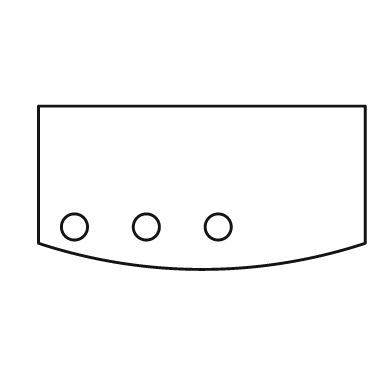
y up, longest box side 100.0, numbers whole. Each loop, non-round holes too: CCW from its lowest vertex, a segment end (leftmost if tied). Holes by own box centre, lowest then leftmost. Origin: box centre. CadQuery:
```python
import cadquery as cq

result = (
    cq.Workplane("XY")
    .moveTo(-50.0, -17.0)
    .threePointArc((0.0, -25.0), (50.0, -17.0))
    .lineTo(50.0, 25.0)
    .lineTo(-50.0, 25.0)
    .close()
    .moveTo(-39.0, -12.0)
    .circle(4.0)
    .moveTo(-17.0, -12.0)
    .circle(4.0)
    .moveTo(5.0, -12.0)
    .circle(4.0)
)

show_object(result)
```